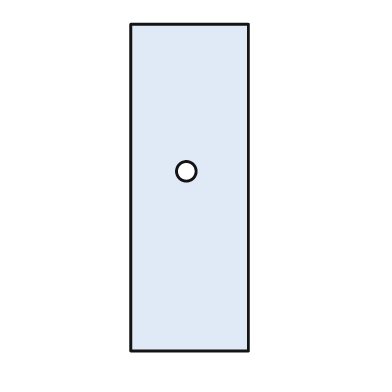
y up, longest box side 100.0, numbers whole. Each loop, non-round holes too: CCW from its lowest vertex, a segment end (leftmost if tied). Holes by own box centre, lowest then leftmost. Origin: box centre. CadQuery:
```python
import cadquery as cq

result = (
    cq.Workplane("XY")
    .moveTo(-18.0, -50.0)
    .lineTo(18.0, -50.0)
    .lineTo(18.0, 50.0)
    .lineTo(-18.0, 50.0)
    .close()
    .moveTo(-1.0, 5.0)
    .circle(3.0)
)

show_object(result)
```